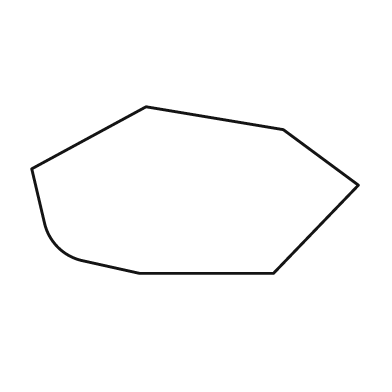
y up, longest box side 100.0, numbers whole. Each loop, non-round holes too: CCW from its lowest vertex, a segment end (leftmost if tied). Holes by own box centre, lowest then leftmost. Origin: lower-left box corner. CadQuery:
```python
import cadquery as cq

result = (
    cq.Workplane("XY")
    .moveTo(33.0, 0.0)
    .lineTo(74.0, 0.0)
    .lineTo(100.0, 27.0)
    .lineTo(77.0, 44.0)
    .lineTo(35.0, 51.0)
    .lineTo(0.0, 32.0)
    .lineTo(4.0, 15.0)
    .threePointArc((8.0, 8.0), (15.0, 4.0))
    .close()
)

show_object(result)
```